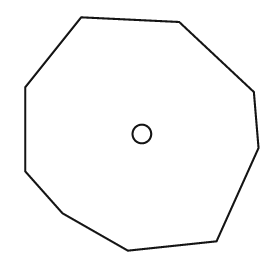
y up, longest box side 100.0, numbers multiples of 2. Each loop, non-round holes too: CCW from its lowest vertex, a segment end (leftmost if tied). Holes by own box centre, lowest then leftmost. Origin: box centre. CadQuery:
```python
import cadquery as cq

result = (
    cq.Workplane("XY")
    .moveTo(-6.0, -50.0)
    .lineTo(32.0, -46.0)
    .lineTo(50.0, -6.0)
    .lineTo(48.0, 18.0)
    .lineTo(16.0, 48.0)
    .lineTo(-26.0, 50.0)
    .lineTo(-50.0, 20.0)
    .lineTo(-50.0, -16.0)
    .lineTo(-34.0, -34.0)
    .close()
    .moveTo(0.0, 0.0)
    .circle(4.0)
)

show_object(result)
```